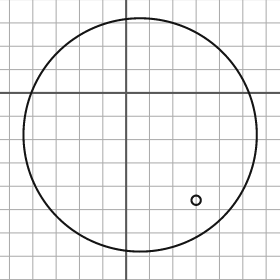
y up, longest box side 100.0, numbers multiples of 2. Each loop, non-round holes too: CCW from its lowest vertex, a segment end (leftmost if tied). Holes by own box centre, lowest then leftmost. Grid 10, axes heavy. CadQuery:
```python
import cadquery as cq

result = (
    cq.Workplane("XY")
    .moveTo(6.0, -18.0)
    .circle(50.0)
    .moveTo(30.0, -46.0)
    .circle(2.0)
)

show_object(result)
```